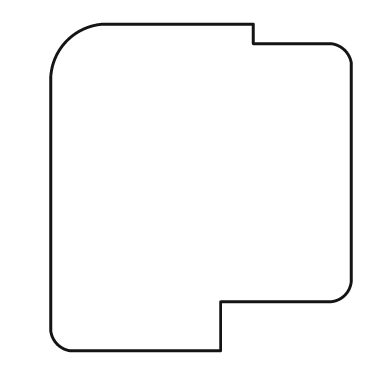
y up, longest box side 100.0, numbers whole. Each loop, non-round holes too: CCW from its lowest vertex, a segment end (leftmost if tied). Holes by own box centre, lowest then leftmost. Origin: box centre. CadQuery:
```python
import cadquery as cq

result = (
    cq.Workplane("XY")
    .moveTo(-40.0, -50.0)
    .lineTo(6.0, -50.0)
    .lineTo(6.0, -35.0)
    .lineTo(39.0, -35.0)
    .threePointArc((44.0, -33.0), (46.0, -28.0))
    .lineTo(46.0, 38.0)
    .threePointArc((44.0, 42.0), (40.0, 44.0))
    .lineTo(16.0, 44.0)
    .lineTo(16.0, 50.0)
    .lineTo(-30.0, 50.0)
    .threePointArc((-41.0, 45.0), (-46.0, 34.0))
    .lineTo(-46.0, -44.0)
    .threePointArc((-44.0, -48.0), (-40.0, -50.0))
    .close()
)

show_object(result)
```